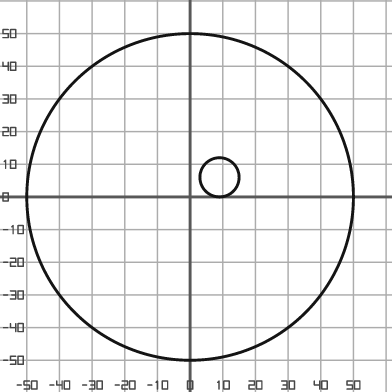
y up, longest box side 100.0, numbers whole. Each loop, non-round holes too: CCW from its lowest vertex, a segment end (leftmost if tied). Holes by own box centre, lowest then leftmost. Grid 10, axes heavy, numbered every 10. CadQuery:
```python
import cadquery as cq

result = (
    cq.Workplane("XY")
    .moveTo(0.0, 0.0)
    .circle(50.0)
    .moveTo(9.0, 6.0)
    .circle(6.0)
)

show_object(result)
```